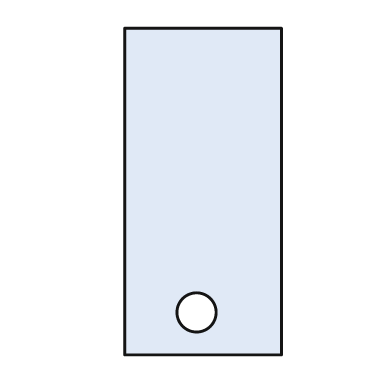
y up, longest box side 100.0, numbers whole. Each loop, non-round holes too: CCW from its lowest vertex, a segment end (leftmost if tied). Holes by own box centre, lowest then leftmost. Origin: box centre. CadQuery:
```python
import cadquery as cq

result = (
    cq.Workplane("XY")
    .moveTo(-24.0, -50.0)
    .lineTo(24.0, -50.0)
    .lineTo(24.0, 50.0)
    .lineTo(-24.0, 50.0)
    .close()
    .moveTo(-2.0, -37.0)
    .circle(6.0)
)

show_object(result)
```